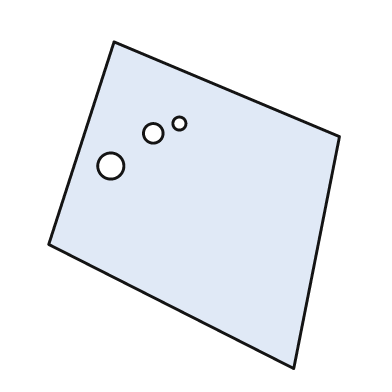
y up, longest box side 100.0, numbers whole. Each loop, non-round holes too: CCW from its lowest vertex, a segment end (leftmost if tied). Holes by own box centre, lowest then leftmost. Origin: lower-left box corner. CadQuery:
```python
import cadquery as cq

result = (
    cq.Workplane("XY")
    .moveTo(75.0, 0.0)
    .lineTo(89.0, 71.0)
    .lineTo(20.0, 100.0)
    .lineTo(0.0, 38.0)
    .close()
    .moveTo(19.0, 62.0)
    .circle(4.0)
    .moveTo(32.0, 72.0)
    .circle(3.0)
    .moveTo(40.0, 75.0)
    .circle(2.0)
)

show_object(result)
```